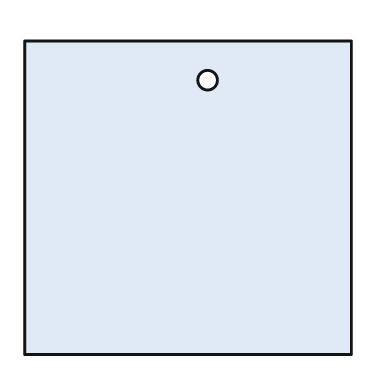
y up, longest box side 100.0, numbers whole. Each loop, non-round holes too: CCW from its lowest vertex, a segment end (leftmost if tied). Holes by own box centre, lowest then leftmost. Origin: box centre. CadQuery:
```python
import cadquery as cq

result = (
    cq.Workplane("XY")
    .moveTo(-50.0, -48.0)
    .lineTo(50.0, -48.0)
    .lineTo(50.0, 48.0)
    .lineTo(-50.0, 48.0)
    .close()
    .moveTo(6.0, 36.0)
    .circle(3.0)
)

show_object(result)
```